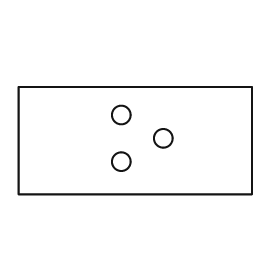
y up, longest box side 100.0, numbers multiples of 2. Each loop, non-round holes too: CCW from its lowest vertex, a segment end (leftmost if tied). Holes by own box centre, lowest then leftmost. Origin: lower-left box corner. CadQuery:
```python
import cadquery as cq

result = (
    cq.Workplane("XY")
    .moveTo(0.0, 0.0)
    .lineTo(100.0, 0.0)
    .lineTo(100.0, 46.0)
    .lineTo(0.0, 46.0)
    .close()
    .moveTo(44.0, 14.0)
    .circle(4.0)
    .moveTo(62.0, 24.0)
    .circle(4.0)
    .moveTo(44.0, 34.0)
    .circle(4.0)
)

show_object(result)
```